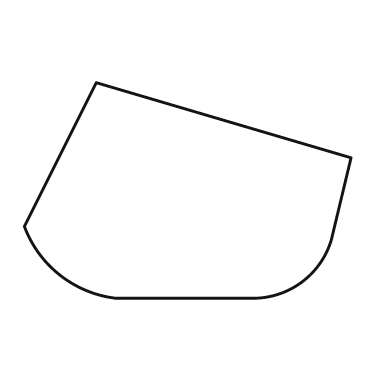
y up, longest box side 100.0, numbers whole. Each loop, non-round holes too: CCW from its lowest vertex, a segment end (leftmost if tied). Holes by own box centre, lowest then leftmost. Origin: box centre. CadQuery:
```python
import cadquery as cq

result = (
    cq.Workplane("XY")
    .moveTo(-22.0, -33.0)
    .lineTo(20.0, -33.0)
    .threePointArc((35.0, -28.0), (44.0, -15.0))
    .lineTo(50.0, 10.0)
    .lineTo(-28.0, 33.0)
    .lineTo(-50.0, -11.0)
    .threePointArc((-39.0, -26.0), (-22.0, -33.0))
    .close()
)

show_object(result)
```